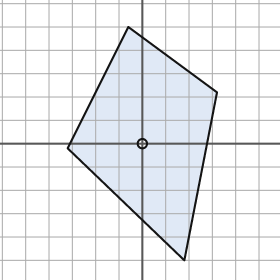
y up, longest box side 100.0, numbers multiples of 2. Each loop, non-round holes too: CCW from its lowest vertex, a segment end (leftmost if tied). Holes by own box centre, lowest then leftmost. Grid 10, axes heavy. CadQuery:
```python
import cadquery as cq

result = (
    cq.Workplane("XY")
    .moveTo(18.0, -50.0)
    .lineTo(32.0, 22.0)
    .lineTo(-6.0, 50.0)
    .lineTo(-32.0, -2.0)
    .close()
    .moveTo(0.0, 0.0)
    .circle(2.0)
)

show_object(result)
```